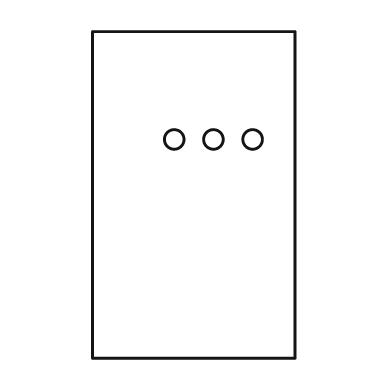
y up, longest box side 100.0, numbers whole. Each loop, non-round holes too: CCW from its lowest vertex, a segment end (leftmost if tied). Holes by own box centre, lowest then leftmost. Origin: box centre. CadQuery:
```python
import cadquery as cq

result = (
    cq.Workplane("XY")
    .moveTo(-31.0, -50.0)
    .lineTo(31.0, -50.0)
    .lineTo(31.0, 50.0)
    .lineTo(-31.0, 50.0)
    .close()
    .moveTo(-6.0, 17.0)
    .circle(3.0)
    .moveTo(6.0, 17.0)
    .circle(3.0)
    .moveTo(18.0, 17.0)
    .circle(3.0)
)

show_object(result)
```